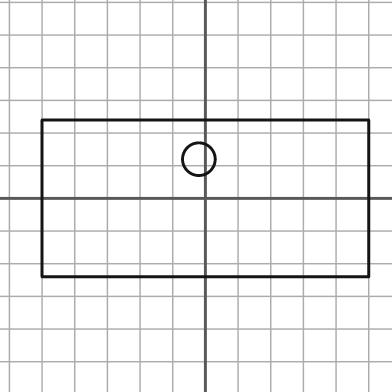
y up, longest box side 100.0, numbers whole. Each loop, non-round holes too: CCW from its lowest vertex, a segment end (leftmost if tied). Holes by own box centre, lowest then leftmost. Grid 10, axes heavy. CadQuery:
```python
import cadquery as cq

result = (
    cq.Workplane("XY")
    .moveTo(-50.0, -24.0)
    .lineTo(50.0, -24.0)
    .lineTo(50.0, 24.0)
    .lineTo(-50.0, 24.0)
    .close()
    .moveTo(-2.0, 12.0)
    .circle(5.0)
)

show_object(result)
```